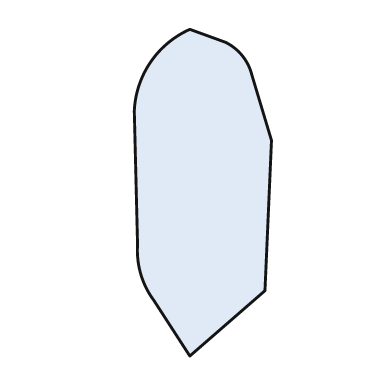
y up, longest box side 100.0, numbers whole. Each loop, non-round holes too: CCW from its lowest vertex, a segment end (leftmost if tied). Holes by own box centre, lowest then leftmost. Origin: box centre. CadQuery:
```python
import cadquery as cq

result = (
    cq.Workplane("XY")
    .moveTo(-4.0, -50.0)
    .lineTo(19.0, -30.0)
    .lineTo(21.0, 16.0)
    .lineTo(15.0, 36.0)
    .threePointArc((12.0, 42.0), (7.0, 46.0))
    .lineTo(-4.0, 50.0)
    .threePointArc((-16.0, 40.0), (-21.0, 25.0))
    .lineTo(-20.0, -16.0)
    .threePointArc((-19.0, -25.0), (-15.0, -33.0))
    .close()
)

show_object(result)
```